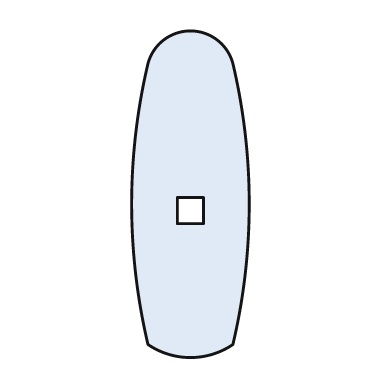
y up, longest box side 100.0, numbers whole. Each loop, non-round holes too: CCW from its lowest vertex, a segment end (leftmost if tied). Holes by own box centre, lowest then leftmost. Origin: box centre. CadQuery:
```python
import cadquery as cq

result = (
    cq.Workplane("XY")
    .moveTo(-13.0, -46.0)
    .threePointArc((0.0, -50.0), (13.0, -46.0))
    .threePointArc((18.0, -3.0), (13.0, 40.0))
    .threePointArc((0.0, 50.0), (-13.0, 40.0))
    .threePointArc((-18.0, -3.0), (-13.0, -46.0))
    .close()
    .moveTo(-4.0, -9.0)
    .lineTo(4.0, -9.0)
    .lineTo(4.0, -1.0)
    .lineTo(-4.0, -1.0)
    .close()
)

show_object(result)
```